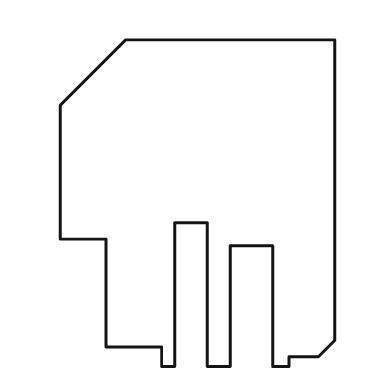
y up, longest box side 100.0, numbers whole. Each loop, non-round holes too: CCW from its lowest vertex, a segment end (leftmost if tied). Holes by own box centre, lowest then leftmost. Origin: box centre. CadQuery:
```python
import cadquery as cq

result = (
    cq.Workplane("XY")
    .moveTo(-11.0, -50.0)
    .lineTo(-7.0, -50.0)
    .lineTo(-7.0, -6.0)
    .lineTo(3.0, -6.0)
    .lineTo(3.0, -50.0)
    .lineTo(10.0, -50.0)
    .lineTo(10.0, -13.0)
    .lineTo(23.0, -13.0)
    .lineTo(23.0, -50.0)
    .lineTo(28.0, -50.0)
    .lineTo(28.0, -47.0)
    .lineTo(37.0, -47.0)
    .lineTo(42.0, -42.0)
    .lineTo(42.0, 50.0)
    .lineTo(-22.0, 50.0)
    .lineTo(-42.0, 30.0)
    .lineTo(-42.0, -11.0)
    .lineTo(-28.0, -11.0)
    .lineTo(-28.0, -44.0)
    .lineTo(-11.0, -44.0)
    .close()
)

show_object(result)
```